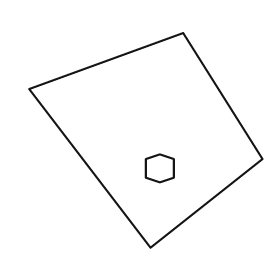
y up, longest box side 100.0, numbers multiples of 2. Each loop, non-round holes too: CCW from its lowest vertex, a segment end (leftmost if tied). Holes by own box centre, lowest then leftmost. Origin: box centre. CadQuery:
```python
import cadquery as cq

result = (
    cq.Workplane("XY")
    .moveTo(2.0, -46.0)
    .lineTo(50.0, -8.0)
    .lineTo(16.0, 46.0)
    .lineTo(-50.0, 22.0)
    .close()
    .moveTo(6.0, -18.0)
    .lineTo(12.0, -16.0)
    .lineTo(12.0, -8.0)
    .lineTo(6.0, -6.0)
    .lineTo(0.0, -8.0)
    .lineTo(0.0, -16.0)
    .close()
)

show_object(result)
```